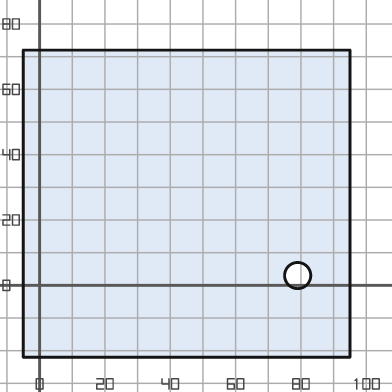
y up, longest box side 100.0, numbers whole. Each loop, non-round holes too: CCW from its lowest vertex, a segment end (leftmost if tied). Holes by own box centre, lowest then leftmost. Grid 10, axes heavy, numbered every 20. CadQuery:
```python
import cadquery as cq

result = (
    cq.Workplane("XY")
    .moveTo(-5.0, -22.0)
    .lineTo(95.0, -22.0)
    .lineTo(95.0, 72.0)
    .lineTo(-5.0, 72.0)
    .close()
    .moveTo(79.0, 3.0)
    .circle(4.0)
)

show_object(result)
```